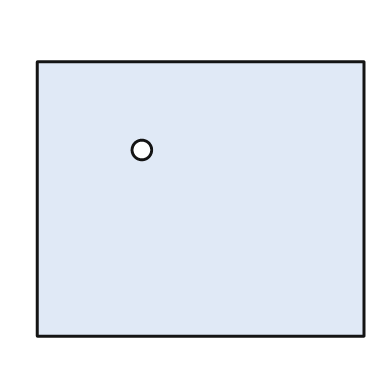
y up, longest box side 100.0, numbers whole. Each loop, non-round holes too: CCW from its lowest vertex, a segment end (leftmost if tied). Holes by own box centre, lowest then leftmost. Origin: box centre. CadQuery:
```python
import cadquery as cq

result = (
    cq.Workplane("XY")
    .moveTo(-50.0, -42.0)
    .lineTo(50.0, -42.0)
    .lineTo(50.0, 42.0)
    .lineTo(-50.0, 42.0)
    .close()
    .moveTo(-18.0, 15.0)
    .circle(3.0)
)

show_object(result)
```